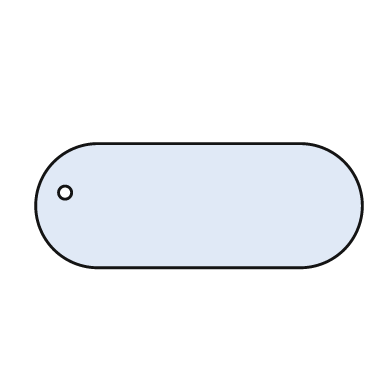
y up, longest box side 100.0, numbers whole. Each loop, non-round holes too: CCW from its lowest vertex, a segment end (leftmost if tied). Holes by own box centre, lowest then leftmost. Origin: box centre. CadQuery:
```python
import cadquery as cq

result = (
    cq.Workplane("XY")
    .moveTo(-31.0, -19.0)
    .lineTo(31.0, -19.0)
    .threePointArc((50.0, 0.0), (31.0, 19.0))
    .lineTo(-31.0, 19.0)
    .threePointArc((-50.0, 0.0), (-31.0, -19.0))
    .close()
    .moveTo(-41.0, 4.0)
    .circle(2.0)
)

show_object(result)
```